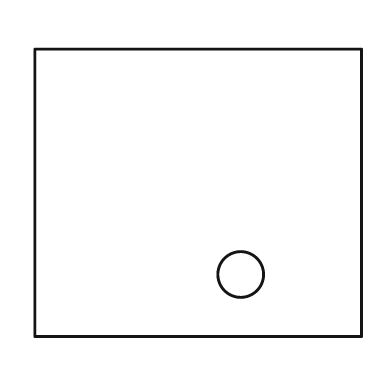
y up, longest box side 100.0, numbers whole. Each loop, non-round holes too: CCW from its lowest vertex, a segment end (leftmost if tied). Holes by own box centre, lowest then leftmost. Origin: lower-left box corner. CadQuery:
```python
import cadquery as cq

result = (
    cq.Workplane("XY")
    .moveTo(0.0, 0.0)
    .lineTo(100.0, 0.0)
    .lineTo(100.0, 88.0)
    .lineTo(0.0, 88.0)
    .close()
    .moveTo(63.0, 19.0)
    .circle(7.0)
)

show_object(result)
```